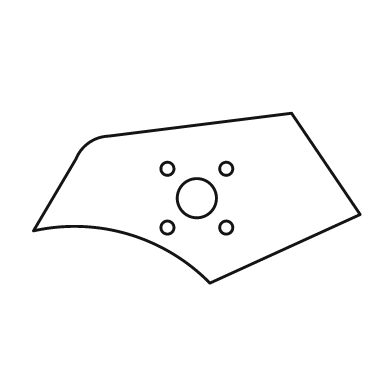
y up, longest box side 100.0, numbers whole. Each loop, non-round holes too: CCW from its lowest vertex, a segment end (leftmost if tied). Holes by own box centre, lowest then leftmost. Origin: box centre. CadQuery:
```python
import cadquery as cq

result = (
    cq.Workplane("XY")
    .moveTo(4.0, -26.0)
    .lineTo(50.0, -5.0)
    .lineTo(29.0, 26.0)
    .lineTo(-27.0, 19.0)
    .threePointArc((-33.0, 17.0), (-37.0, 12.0))
    .lineTo(-50.0, -10.0)
    .threePointArc((-21.0, -11.0), (4.0, -26.0))
    .close()
    .moveTo(-9.0, -9.0)
    .circle(2.0)
    .moveTo(9.0, -9.0)
    .circle(2.0)
    .moveTo(0.0, 0.0)
    .circle(6.0)
    .moveTo(-9.0, 9.0)
    .circle(2.0)
    .moveTo(9.0, 9.0)
    .circle(2.0)
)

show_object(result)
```